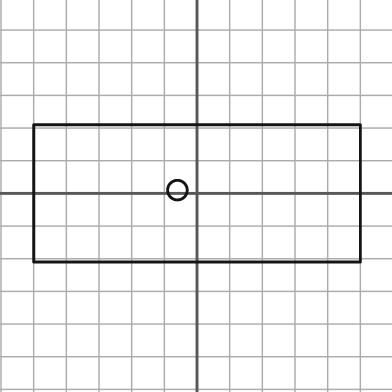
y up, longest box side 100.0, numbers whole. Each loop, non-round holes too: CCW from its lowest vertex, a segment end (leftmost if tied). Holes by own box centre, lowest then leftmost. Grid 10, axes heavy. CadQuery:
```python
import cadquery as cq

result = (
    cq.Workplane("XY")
    .moveTo(-50.0, -21.0)
    .lineTo(50.0, -21.0)
    .lineTo(50.0, 21.0)
    .lineTo(-50.0, 21.0)
    .close()
    .moveTo(-6.0, 1.0)
    .circle(3.0)
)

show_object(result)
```